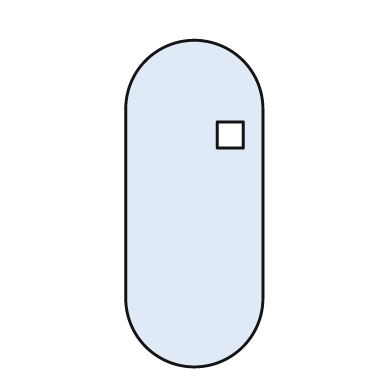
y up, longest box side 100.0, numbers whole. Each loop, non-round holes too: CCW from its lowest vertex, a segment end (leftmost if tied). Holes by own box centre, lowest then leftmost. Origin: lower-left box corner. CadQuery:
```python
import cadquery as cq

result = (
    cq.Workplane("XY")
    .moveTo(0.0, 21.0)
    .threePointArc((21.0, 0.0), (42.0, 21.0))
    .lineTo(42.0, 79.0)
    .threePointArc((21.0, 100.0), (0.0, 79.0))
    .close()
    .moveTo(28.0, 67.0)
    .lineTo(36.0, 67.0)
    .lineTo(36.0, 75.0)
    .lineTo(28.0, 75.0)
    .close()
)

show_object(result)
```